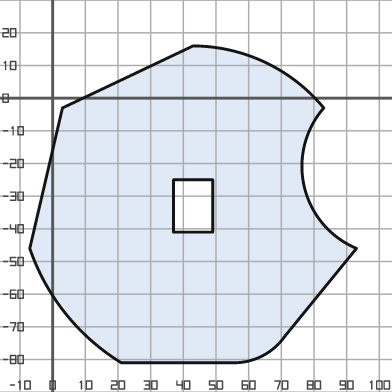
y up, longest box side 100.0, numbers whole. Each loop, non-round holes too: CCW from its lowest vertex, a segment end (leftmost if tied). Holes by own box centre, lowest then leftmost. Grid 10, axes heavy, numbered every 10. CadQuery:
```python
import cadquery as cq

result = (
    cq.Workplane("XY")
    .moveTo(21.0, -81.0)
    .lineTo(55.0, -81.0)
    .threePointArc((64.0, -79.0), (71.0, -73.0))
    .lineTo(93.0, -46.0)
    .threePointArc((77.0, -27.0), (83.0, -3.0))
    .threePointArc((65.0, 11.0), (43.0, 16.0))
    .lineTo(3.0, -3.0)
    .lineTo(-7.0, -46.0)
    .threePointArc((4.0, -66.0), (21.0, -81.0))
    .close()
    .moveTo(37.0, -41.0)
    .lineTo(49.0, -41.0)
    .lineTo(49.0, -25.0)
    .lineTo(37.0, -25.0)
    .close()
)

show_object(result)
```